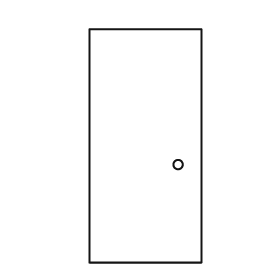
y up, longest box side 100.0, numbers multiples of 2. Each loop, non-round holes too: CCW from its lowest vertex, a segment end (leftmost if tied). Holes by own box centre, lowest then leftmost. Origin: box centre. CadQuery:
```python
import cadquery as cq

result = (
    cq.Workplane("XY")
    .moveTo(-24.0, -50.0)
    .lineTo(24.0, -50.0)
    .lineTo(24.0, 50.0)
    .lineTo(-24.0, 50.0)
    .close()
    .moveTo(14.0, -8.0)
    .circle(2.0)
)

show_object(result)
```